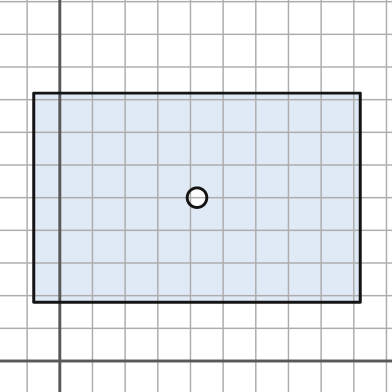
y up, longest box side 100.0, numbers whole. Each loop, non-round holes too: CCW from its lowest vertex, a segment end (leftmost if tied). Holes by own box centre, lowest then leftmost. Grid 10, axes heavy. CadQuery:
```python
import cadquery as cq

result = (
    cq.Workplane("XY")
    .moveTo(-8.0, 18.0)
    .lineTo(92.0, 18.0)
    .lineTo(92.0, 82.0)
    .lineTo(-8.0, 82.0)
    .close()
    .moveTo(42.0, 50.0)
    .circle(3.0)
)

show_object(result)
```